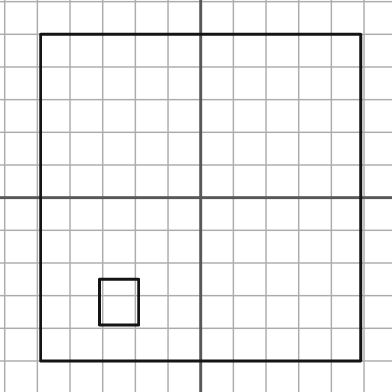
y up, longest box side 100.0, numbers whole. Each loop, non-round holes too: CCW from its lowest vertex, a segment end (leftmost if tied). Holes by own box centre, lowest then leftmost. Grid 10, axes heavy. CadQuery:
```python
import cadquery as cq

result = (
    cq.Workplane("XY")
    .moveTo(-49.0, -50.0)
    .lineTo(49.0, -50.0)
    .lineTo(49.0, 50.0)
    .lineTo(-49.0, 50.0)
    .close()
    .moveTo(-31.0, -39.0)
    .lineTo(-19.0, -39.0)
    .lineTo(-19.0, -25.0)
    .lineTo(-31.0, -25.0)
    .close()
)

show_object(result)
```